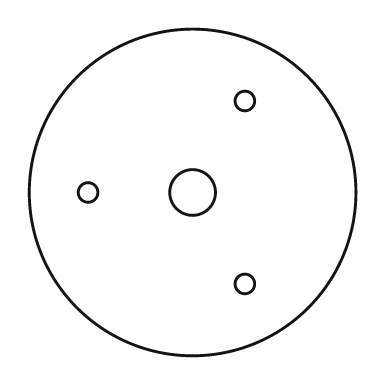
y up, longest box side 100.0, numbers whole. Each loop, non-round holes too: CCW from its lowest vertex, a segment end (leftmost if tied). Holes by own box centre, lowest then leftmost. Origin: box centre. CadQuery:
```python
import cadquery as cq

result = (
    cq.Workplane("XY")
    .moveTo(0.0, 0.0)
    .circle(50.0)
    .moveTo(16.0, -28.0)
    .circle(3.0)
    .moveTo(-32.0, 0.0)
    .circle(3.0)
    .moveTo(0.0, 0.0)
    .circle(7.0)
    .moveTo(16.0, 28.0)
    .circle(3.0)
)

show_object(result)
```